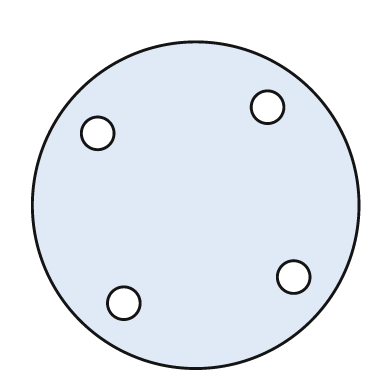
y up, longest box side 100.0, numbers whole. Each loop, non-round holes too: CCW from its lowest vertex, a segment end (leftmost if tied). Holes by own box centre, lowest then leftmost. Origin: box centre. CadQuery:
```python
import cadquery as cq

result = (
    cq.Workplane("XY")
    .moveTo(0.0, 0.0)
    .circle(50.0)
    .moveTo(-22.0, -30.0)
    .circle(5.0)
    .moveTo(30.0, -22.0)
    .circle(5.0)
    .moveTo(-30.0, 22.0)
    .circle(5.0)
    .moveTo(22.0, 30.0)
    .circle(5.0)
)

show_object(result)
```